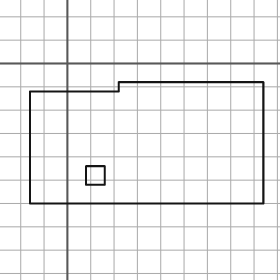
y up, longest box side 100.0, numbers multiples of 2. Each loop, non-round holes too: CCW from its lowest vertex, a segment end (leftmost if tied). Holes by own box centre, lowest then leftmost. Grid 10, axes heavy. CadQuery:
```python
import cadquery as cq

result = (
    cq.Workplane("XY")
    .moveTo(-16.0, -60.0)
    .lineTo(84.0, -60.0)
    .lineTo(84.0, -8.0)
    .lineTo(22.0, -8.0)
    .lineTo(22.0, -12.0)
    .lineTo(-16.0, -12.0)
    .close()
    .moveTo(8.0, -52.0)
    .lineTo(16.0, -52.0)
    .lineTo(16.0, -44.0)
    .lineTo(8.0, -44.0)
    .close()
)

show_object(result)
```